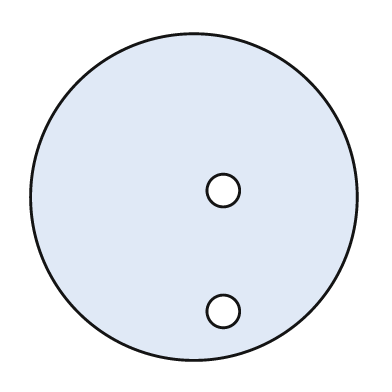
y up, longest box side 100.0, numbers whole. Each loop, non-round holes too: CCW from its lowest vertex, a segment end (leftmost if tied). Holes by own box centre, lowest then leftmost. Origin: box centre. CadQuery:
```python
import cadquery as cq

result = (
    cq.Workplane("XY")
    .moveTo(0.0, 0.0)
    .circle(50.0)
    .moveTo(9.0, -35.0)
    .circle(5.0)
    .moveTo(9.0, 2.0)
    .circle(5.0)
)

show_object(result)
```